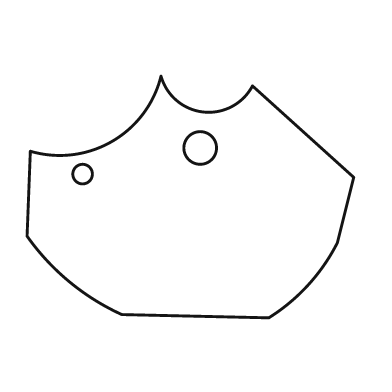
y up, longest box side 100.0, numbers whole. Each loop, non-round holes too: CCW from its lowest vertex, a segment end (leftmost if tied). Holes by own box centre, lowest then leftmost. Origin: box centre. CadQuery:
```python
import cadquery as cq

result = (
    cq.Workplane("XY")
    .moveTo(24.0, -37.0)
    .threePointArc((36.0, -27.0), (45.0, -14.0))
    .lineTo(50.0, 6.0)
    .lineTo(19.0, 34.0)
    .threePointArc((4.0, 26.0), (-9.0, 37.0))
    .threePointArc((-24.0, 17.0), (-49.0, 14.0))
    .lineTo(-50.0, -12.0)
    .threePointArc((-37.0, -26.0), (-21.0, -36.0))
    .close()
    .moveTo(-33.0, 7.0)
    .circle(3.0)
    .moveTo(3.0, 15.0)
    .circle(5.0)
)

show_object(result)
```